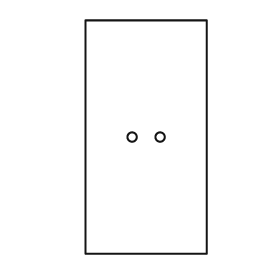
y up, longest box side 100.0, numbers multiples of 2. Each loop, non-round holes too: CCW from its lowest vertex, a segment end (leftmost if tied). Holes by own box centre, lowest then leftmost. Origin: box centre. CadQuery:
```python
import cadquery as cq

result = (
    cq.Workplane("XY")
    .moveTo(-26.0, -50.0)
    .lineTo(26.0, -50.0)
    .lineTo(26.0, 50.0)
    .lineTo(-26.0, 50.0)
    .close()
    .moveTo(-6.0, 0.0)
    .circle(2.0)
    .moveTo(6.0, 0.0)
    .circle(2.0)
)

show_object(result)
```